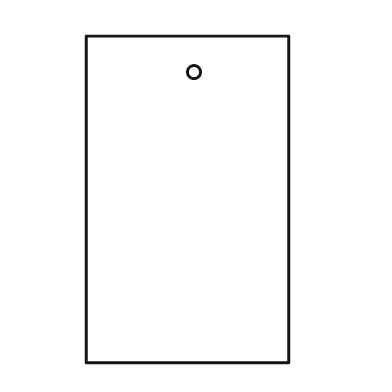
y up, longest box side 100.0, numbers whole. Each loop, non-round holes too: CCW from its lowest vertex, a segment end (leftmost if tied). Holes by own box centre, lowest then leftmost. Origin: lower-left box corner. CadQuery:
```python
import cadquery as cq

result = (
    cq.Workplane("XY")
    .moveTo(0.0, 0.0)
    .lineTo(62.0, 0.0)
    .lineTo(62.0, 100.0)
    .lineTo(0.0, 100.0)
    .close()
    .moveTo(33.0, 89.0)
    .circle(2.0)
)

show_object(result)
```